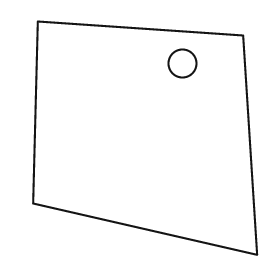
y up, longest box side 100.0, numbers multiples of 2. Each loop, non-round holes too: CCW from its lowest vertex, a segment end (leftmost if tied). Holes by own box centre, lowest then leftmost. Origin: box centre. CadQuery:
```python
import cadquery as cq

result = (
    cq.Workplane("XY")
    .moveTo(48.0, -50.0)
    .lineTo(42.0, 44.0)
    .lineTo(-46.0, 50.0)
    .lineTo(-48.0, -28.0)
    .close()
    .moveTo(16.0, 32.0)
    .circle(6.0)
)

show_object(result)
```